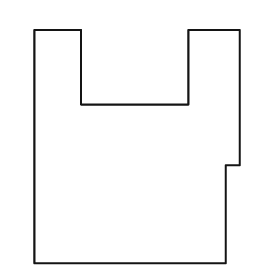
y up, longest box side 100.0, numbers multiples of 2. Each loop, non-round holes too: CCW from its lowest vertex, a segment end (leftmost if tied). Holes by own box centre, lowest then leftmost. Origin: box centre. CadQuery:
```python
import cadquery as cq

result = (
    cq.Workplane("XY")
    .moveTo(-44.0, -50.0)
    .lineTo(38.0, -50.0)
    .lineTo(38.0, -8.0)
    .lineTo(44.0, -8.0)
    .lineTo(44.0, 50.0)
    .lineTo(22.0, 50.0)
    .lineTo(22.0, 18.0)
    .lineTo(-24.0, 18.0)
    .lineTo(-24.0, 50.0)
    .lineTo(-44.0, 50.0)
    .close()
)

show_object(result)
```